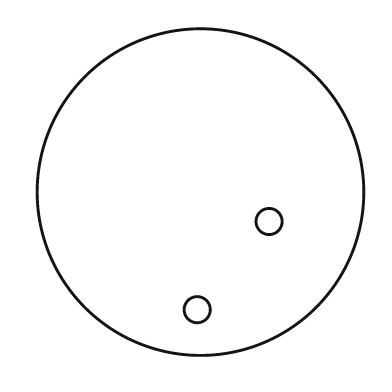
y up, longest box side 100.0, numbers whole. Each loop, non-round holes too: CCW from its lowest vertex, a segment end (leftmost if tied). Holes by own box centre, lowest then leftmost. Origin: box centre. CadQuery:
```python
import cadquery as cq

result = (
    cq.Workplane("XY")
    .moveTo(0.0, 0.0)
    .circle(50.0)
    .moveTo(-1.0, -36.0)
    .circle(4.0)
    .moveTo(21.0, -9.0)
    .circle(4.0)
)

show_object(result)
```